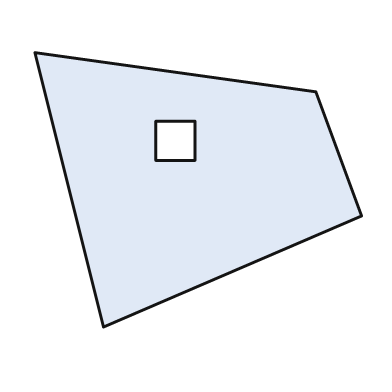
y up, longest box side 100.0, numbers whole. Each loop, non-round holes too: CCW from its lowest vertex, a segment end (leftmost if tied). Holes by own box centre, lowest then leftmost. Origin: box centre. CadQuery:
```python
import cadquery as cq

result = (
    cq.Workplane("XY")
    .moveTo(-29.0, -42.0)
    .lineTo(50.0, -8.0)
    .lineTo(36.0, 30.0)
    .lineTo(-50.0, 42.0)
    .close()
    .moveTo(-13.0, 9.0)
    .lineTo(-1.0, 9.0)
    .lineTo(-1.0, 21.0)
    .lineTo(-13.0, 21.0)
    .close()
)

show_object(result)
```